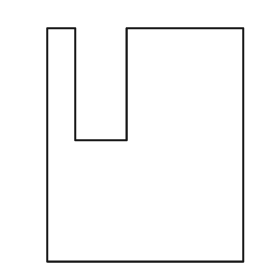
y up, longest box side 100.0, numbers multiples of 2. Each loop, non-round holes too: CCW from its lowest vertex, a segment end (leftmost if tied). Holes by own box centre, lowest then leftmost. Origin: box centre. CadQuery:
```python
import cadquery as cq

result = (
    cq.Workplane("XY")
    .moveTo(-42.0, -50.0)
    .lineTo(42.0, -50.0)
    .lineTo(42.0, 50.0)
    .lineTo(-8.0, 50.0)
    .lineTo(-8.0, 2.0)
    .lineTo(-30.0, 2.0)
    .lineTo(-30.0, 50.0)
    .lineTo(-42.0, 50.0)
    .close()
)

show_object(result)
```